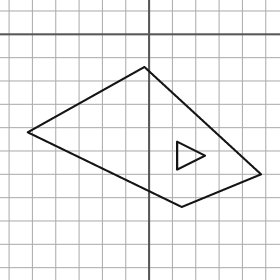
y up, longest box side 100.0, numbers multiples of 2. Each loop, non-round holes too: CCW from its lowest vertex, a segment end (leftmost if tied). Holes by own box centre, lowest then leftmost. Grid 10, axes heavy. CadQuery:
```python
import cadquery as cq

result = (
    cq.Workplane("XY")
    .moveTo(14.0, -74.0)
    .lineTo(48.0, -60.0)
    .lineTo(-2.0, -14.0)
    .lineTo(-52.0, -42.0)
    .close()
    .moveTo(12.0, -58.0)
    .lineTo(24.0, -52.0)
    .lineTo(12.0, -46.0)
    .close()
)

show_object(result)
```